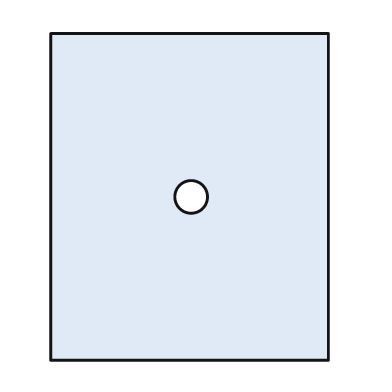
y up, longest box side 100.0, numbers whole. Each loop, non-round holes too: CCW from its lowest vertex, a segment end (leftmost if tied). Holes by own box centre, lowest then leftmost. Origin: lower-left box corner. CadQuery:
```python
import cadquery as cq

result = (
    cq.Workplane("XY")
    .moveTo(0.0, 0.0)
    .lineTo(85.0, 0.0)
    .lineTo(85.0, 100.0)
    .lineTo(0.0, 100.0)
    .close()
    .moveTo(43.0, 50.0)
    .circle(5.0)
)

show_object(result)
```